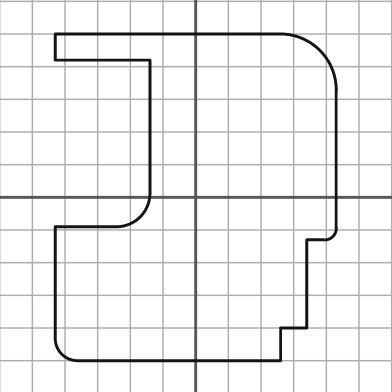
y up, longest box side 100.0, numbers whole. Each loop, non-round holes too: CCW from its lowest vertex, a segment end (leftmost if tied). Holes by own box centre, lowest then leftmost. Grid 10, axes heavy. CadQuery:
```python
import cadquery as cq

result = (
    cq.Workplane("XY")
    .moveTo(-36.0, -50.0)
    .lineTo(26.0, -50.0)
    .lineTo(26.0, -40.0)
    .lineTo(34.0, -40.0)
    .lineTo(34.0, -13.0)
    .lineTo(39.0, -13.0)
    .threePointArc((42.0, -12.0), (43.0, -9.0))
    .lineTo(43.0, 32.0)
    .threePointArc((38.0, 45.0), (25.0, 50.0))
    .lineTo(-43.0, 50.0)
    .lineTo(-43.0, 42.0)
    .lineTo(-14.0, 42.0)
    .lineTo(-14.0, 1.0)
    .threePointArc((-17.0, -6.0), (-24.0, -9.0))
    .lineTo(-43.0, -9.0)
    .lineTo(-43.0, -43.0)
    .threePointArc((-41.0, -48.0), (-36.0, -50.0))
    .close()
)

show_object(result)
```